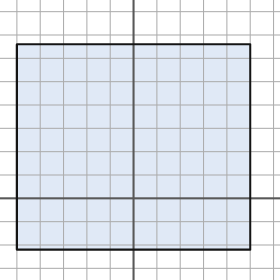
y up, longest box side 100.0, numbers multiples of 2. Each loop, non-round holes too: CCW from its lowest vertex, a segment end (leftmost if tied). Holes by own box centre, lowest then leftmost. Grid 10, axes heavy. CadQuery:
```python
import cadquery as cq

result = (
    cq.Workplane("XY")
    .moveTo(-50.0, -22.0)
    .lineTo(50.0, -22.0)
    .lineTo(50.0, 66.0)
    .lineTo(-50.0, 66.0)
    .close()
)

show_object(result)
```